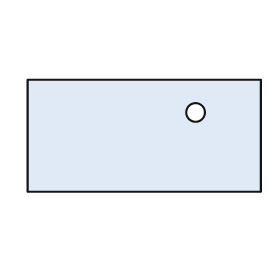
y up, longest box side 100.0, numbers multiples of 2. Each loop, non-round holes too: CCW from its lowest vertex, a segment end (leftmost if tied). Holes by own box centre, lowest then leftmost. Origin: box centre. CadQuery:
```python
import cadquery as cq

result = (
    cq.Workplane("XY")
    .moveTo(-50.0, -24.0)
    .lineTo(50.0, -24.0)
    .lineTo(50.0, 24.0)
    .lineTo(-50.0, 24.0)
    .close()
    .moveTo(22.0, 10.0)
    .circle(4.0)
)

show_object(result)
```